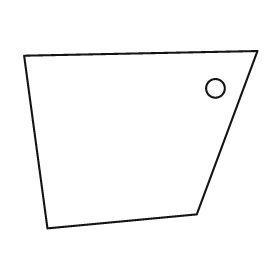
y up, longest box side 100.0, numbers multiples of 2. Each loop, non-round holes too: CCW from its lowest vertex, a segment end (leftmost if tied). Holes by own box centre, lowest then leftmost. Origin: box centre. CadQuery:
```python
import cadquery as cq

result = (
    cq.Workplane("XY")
    .moveTo(-40.0, -38.0)
    .lineTo(24.0, -32.0)
    .lineTo(50.0, 38.0)
    .lineTo(-50.0, 36.0)
    .close()
    .moveTo(32.0, 22.0)
    .circle(4.0)
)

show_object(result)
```